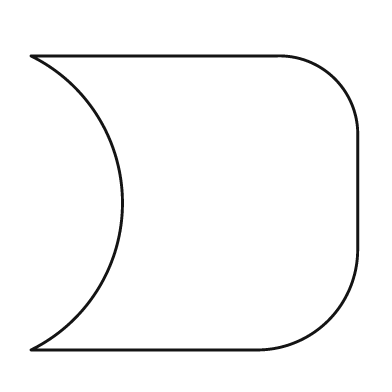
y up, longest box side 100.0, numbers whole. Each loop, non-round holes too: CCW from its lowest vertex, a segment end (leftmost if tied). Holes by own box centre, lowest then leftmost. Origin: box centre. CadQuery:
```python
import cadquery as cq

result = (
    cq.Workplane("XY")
    .moveTo(-50.0, -45.0)
    .lineTo(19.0, -45.0)
    .threePointArc((41.0, -36.0), (50.0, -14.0))
    .lineTo(50.0, 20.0)
    .threePointArc((43.0, 38.0), (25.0, 45.0))
    .lineTo(-50.0, 45.0)
    .threePointArc((-22.0, 0.0), (-50.0, -45.0))
    .close()
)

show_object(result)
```